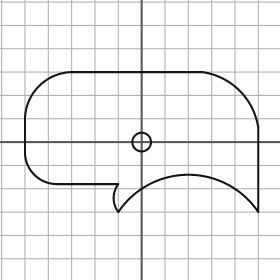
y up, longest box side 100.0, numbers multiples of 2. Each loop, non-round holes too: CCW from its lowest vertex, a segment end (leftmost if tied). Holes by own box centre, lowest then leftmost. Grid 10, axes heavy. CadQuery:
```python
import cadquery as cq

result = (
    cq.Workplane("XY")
    .moveTo(-10.0, -30.0)
    .threePointArc((20.0, -14.0), (50.0, -30.0))
    .lineTo(50.0, 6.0)
    .threePointArc((42.0, 22.0), (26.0, 30.0))
    .lineTo(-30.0, 30.0)
    .threePointArc((-44.0, 24.0), (-50.0, 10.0))
    .lineTo(-50.0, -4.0)
    .threePointArc((-46.0, -14.0), (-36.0, -18.0))
    .lineTo(-10.0, -18.0)
    .threePointArc((-12.0, -24.0), (-10.0, -30.0))
    .close()
    .moveTo(0.0, 0.0)
    .circle(4.0)
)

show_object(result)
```